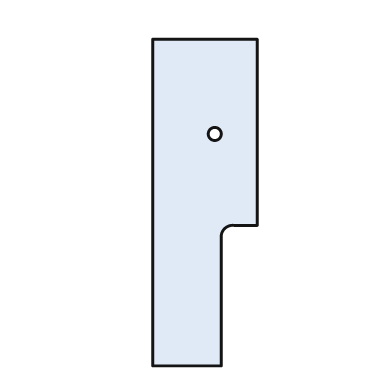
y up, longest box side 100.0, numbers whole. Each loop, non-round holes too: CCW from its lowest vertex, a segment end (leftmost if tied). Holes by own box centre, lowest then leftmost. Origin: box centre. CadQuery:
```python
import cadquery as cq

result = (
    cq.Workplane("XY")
    .moveTo(-16.0, -50.0)
    .lineTo(5.0, -50.0)
    .lineTo(5.0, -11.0)
    .threePointArc((6.0, -8.0), (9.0, -7.0))
    .lineTo(16.0, -7.0)
    .lineTo(16.0, 50.0)
    .lineTo(-16.0, 50.0)
    .close()
    .moveTo(3.0, 21.0)
    .circle(2.0)
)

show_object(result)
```